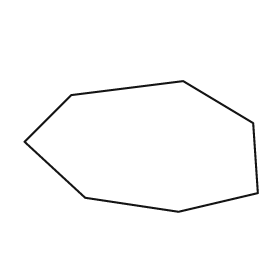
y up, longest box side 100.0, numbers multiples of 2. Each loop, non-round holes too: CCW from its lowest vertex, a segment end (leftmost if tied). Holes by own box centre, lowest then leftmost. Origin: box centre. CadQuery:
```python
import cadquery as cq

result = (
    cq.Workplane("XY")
    .moveTo(16.0, -28.0)
    .lineTo(50.0, -20.0)
    .lineTo(48.0, 10.0)
    .lineTo(18.0, 28.0)
    .lineTo(-30.0, 22.0)
    .lineTo(-50.0, 2.0)
    .lineTo(-24.0, -22.0)
    .close()
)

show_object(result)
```